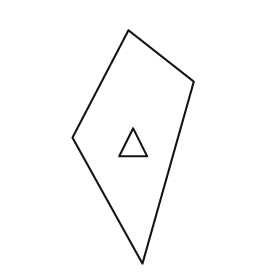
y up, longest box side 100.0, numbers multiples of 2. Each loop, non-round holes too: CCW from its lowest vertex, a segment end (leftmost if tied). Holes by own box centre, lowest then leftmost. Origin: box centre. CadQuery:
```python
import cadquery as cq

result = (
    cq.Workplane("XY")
    .moveTo(4.0, -50.0)
    .lineTo(26.0, 28.0)
    .lineTo(-2.0, 50.0)
    .lineTo(-26.0, 4.0)
    .close()
    .moveTo(-6.0, -4.0)
    .lineTo(6.0, -4.0)
    .lineTo(0.0, 8.0)
    .close()
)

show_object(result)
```